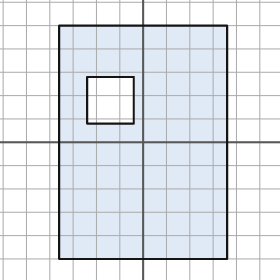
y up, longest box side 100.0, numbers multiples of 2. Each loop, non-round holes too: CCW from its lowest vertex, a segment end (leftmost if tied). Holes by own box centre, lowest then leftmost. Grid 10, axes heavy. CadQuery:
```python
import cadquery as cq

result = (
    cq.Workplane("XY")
    .moveTo(-36.0, -50.0)
    .lineTo(36.0, -50.0)
    .lineTo(36.0, 50.0)
    .lineTo(-36.0, 50.0)
    .close()
    .moveTo(-24.0, 8.0)
    .lineTo(-4.0, 8.0)
    .lineTo(-4.0, 28.0)
    .lineTo(-24.0, 28.0)
    .close()
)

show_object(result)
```